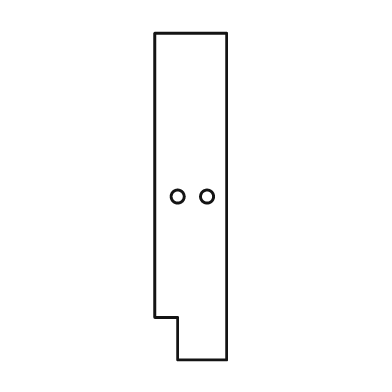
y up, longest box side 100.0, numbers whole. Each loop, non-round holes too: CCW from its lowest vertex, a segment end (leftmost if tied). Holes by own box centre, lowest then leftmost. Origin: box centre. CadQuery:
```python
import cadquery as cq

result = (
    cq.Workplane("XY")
    .moveTo(-4.0, -50.0)
    .lineTo(11.0, -50.0)
    .lineTo(11.0, 50.0)
    .lineTo(-11.0, 50.0)
    .lineTo(-11.0, -37.0)
    .lineTo(-4.0, -37.0)
    .close()
    .moveTo(-4.0, 0.0)
    .circle(2.0)
    .moveTo(5.0, 0.0)
    .circle(2.0)
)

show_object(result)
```